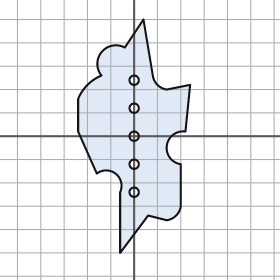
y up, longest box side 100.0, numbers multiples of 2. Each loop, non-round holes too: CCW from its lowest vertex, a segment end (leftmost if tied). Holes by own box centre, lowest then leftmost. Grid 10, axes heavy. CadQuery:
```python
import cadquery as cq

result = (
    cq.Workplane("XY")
    .moveTo(-6.0, -50.0)
    .lineTo(6.0, -34.0)
    .lineTo(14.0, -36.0)
    .threePointArc((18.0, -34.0), (20.0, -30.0))
    .lineTo(20.0, -12.0)
    .threePointArc((14.0, -4.0), (22.0, 2.0))
    .lineTo(24.0, 22.0)
    .lineTo(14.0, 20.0)
    .threePointArc((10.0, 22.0), (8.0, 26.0))
    .lineTo(4.0, 50.0)
    .lineTo(-4.0, 38.0)
    .threePointArc((-14.0, 36.0), (-14.0, 26.0))
    .threePointArc((-20.0, 22.0), (-24.0, 16.0))
    .lineTo(-24.0, 2.0)
    .lineTo(-16.0, -16.0)
    .threePointArc((-8.0, -16.0), (-6.0, -24.0))
    .close()
    .moveTo(0.0, -24.0)
    .circle(2.0)
    .moveTo(0.0, -12.0)
    .circle(2.0)
    .moveTo(0.0, 0.0)
    .circle(2.0)
    .moveTo(0.0, 12.0)
    .circle(2.0)
    .moveTo(0.0, 24.0)
    .circle(2.0)
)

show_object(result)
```